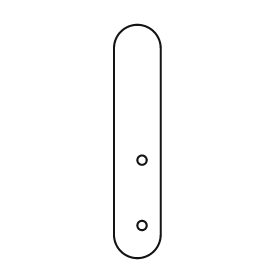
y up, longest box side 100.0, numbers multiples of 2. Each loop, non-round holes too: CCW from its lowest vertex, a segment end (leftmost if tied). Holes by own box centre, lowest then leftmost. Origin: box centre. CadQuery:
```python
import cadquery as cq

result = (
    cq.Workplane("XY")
    .moveTo(-10.0, -40.0)
    .threePointArc((0.0, -50.0), (10.0, -40.0))
    .lineTo(10.0, 40.0)
    .threePointArc((0.0, 50.0), (-10.0, 40.0))
    .close()
    .moveTo(2.0, -36.0)
    .circle(2.0)
    .moveTo(2.0, -8.0)
    .circle(2.0)
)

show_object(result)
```